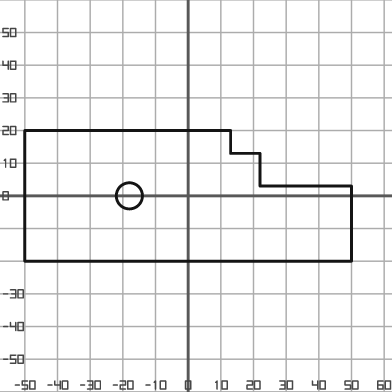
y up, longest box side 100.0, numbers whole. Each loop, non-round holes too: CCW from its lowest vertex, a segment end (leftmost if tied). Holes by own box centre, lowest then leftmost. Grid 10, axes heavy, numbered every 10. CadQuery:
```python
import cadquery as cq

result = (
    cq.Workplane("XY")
    .moveTo(-50.0, -20.0)
    .lineTo(50.0, -20.0)
    .lineTo(50.0, 3.0)
    .lineTo(22.0, 3.0)
    .lineTo(22.0, 13.0)
    .lineTo(13.0, 13.0)
    .lineTo(13.0, 20.0)
    .lineTo(-50.0, 20.0)
    .close()
    .moveTo(-18.0, 0.0)
    .circle(4.0)
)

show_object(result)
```